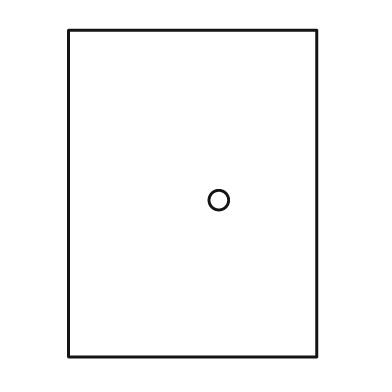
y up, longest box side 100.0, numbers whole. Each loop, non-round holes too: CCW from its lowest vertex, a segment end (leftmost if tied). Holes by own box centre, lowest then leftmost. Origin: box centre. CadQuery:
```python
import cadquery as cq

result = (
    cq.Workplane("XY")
    .moveTo(-38.0, -50.0)
    .lineTo(38.0, -50.0)
    .lineTo(38.0, 50.0)
    .lineTo(-38.0, 50.0)
    .close()
    .moveTo(8.0, -2.0)
    .circle(3.0)
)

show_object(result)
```